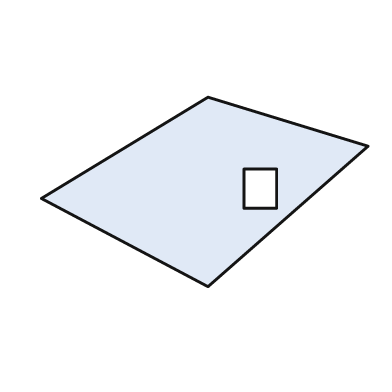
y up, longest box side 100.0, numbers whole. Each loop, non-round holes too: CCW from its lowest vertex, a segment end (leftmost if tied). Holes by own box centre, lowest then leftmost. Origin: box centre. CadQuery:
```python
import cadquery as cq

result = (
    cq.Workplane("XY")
    .moveTo(1.0, -29.0)
    .lineTo(50.0, 14.0)
    .lineTo(1.0, 29.0)
    .lineTo(-50.0, -2.0)
    .close()
    .moveTo(12.0, -5.0)
    .lineTo(22.0, -5.0)
    .lineTo(22.0, 7.0)
    .lineTo(12.0, 7.0)
    .close()
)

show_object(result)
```